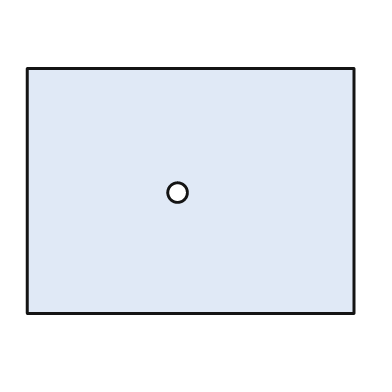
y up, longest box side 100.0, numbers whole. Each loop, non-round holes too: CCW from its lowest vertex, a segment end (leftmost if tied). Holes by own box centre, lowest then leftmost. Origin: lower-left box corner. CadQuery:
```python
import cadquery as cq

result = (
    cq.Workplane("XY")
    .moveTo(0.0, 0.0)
    .lineTo(100.0, 0.0)
    .lineTo(100.0, 75.0)
    .lineTo(0.0, 75.0)
    .close()
    .moveTo(46.0, 37.0)
    .circle(3.0)
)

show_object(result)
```